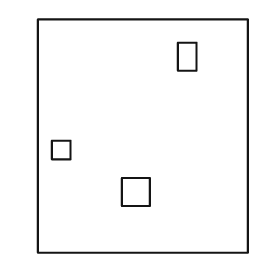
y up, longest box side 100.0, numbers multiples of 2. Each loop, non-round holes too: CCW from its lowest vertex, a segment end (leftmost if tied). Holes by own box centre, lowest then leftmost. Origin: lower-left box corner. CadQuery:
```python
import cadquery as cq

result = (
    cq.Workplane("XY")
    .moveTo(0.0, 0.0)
    .lineTo(90.0, 0.0)
    .lineTo(90.0, 100.0)
    .lineTo(0.0, 100.0)
    .close()
    .moveTo(36.0, 20.0)
    .lineTo(48.0, 20.0)
    .lineTo(48.0, 32.0)
    .lineTo(36.0, 32.0)
    .close()
    .moveTo(6.0, 40.0)
    .lineTo(14.0, 40.0)
    .lineTo(14.0, 48.0)
    .lineTo(6.0, 48.0)
    .close()
    .moveTo(60.0, 78.0)
    .lineTo(68.0, 78.0)
    .lineTo(68.0, 90.0)
    .lineTo(60.0, 90.0)
    .close()
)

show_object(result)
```